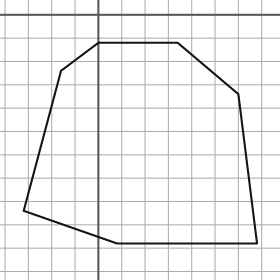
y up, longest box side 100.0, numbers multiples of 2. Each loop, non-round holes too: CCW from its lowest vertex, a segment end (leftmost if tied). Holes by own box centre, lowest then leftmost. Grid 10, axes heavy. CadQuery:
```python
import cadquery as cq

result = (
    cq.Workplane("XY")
    .moveTo(8.0, -98.0)
    .lineTo(68.0, -98.0)
    .lineTo(60.0, -34.0)
    .lineTo(34.0, -12.0)
    .lineTo(0.0, -12.0)
    .lineTo(-16.0, -24.0)
    .lineTo(-32.0, -84.0)
    .close()
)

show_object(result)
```